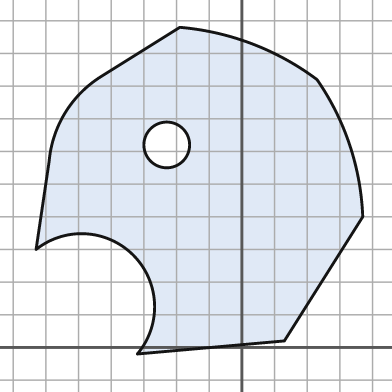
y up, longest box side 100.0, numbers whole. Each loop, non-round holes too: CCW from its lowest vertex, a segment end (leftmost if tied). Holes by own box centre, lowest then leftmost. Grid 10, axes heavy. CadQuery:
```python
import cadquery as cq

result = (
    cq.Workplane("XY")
    .moveTo(-32.0, -2.0)
    .lineTo(13.0, 2.0)
    .lineTo(37.0, 40.0)
    .threePointArc((33.0, 62.0), (23.0, 82.0))
    .threePointArc((3.0, 93.0), (-19.0, 98.0))
    .lineTo(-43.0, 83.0)
    .threePointArc((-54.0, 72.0), (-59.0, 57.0))
    .lineTo(-63.0, 30.0)
    .threePointArc((-33.0, 28.0), (-32.0, -2.0))
    .close()
    .moveTo(-23.0, 62.0)
    .circle(7.0)
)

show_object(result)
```